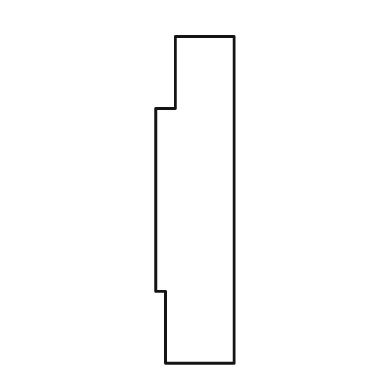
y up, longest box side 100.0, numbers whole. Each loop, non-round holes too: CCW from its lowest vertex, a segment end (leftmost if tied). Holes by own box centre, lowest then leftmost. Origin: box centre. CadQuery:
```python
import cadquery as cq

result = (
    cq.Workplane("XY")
    .moveTo(-9.0, -50.0)
    .lineTo(12.0, -50.0)
    .lineTo(12.0, 50.0)
    .lineTo(-6.0, 50.0)
    .lineTo(-6.0, 28.0)
    .lineTo(-12.0, 28.0)
    .lineTo(-12.0, -28.0)
    .lineTo(-9.0, -28.0)
    .close()
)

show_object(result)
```